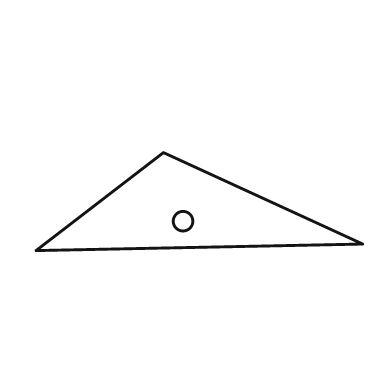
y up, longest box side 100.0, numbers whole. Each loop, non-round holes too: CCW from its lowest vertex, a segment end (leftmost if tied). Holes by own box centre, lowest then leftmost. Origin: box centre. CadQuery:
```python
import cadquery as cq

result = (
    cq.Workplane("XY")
    .moveTo(-50.0, -15.0)
    .lineTo(50.0, -13.0)
    .lineTo(-11.0, 15.0)
    .close()
    .moveTo(-5.0, -6.0)
    .circle(3.0)
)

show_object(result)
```